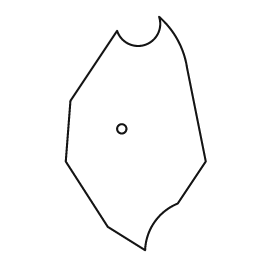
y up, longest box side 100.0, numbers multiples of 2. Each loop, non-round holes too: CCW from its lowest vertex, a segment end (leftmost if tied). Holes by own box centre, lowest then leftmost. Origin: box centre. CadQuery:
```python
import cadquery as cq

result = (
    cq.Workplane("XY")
    .moveTo(4.0, -50.0)
    .threePointArc((8.0, -38.0), (18.0, -30.0))
    .lineTo(30.0, -12.0)
    .lineTo(22.0, 28.0)
    .threePointArc((18.0, 40.0), (10.0, 50.0))
    .threePointArc((4.0, 38.0), (-8.0, 44.0))
    .lineTo(-28.0, 14.0)
    .lineTo(-30.0, -12.0)
    .lineTo(-12.0, -40.0)
    .close()
    .moveTo(-6.0, 2.0)
    .circle(2.0)
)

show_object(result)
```